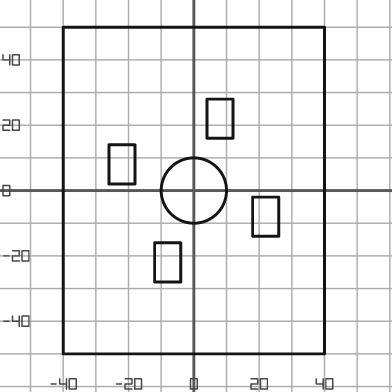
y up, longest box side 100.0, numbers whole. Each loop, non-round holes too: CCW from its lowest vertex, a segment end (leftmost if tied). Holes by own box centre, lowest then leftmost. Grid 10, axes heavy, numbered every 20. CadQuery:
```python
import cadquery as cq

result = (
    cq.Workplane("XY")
    .moveTo(-40.0, -50.0)
    .lineTo(40.0, -50.0)
    .lineTo(40.0, 50.0)
    .lineTo(-40.0, 50.0)
    .close()
    .moveTo(-12.0, -28.0)
    .lineTo(-4.0, -28.0)
    .lineTo(-4.0, -16.0)
    .lineTo(-12.0, -16.0)
    .close()
    .moveTo(18.0, -14.0)
    .lineTo(26.0, -14.0)
    .lineTo(26.0, -2.0)
    .lineTo(18.0, -2.0)
    .close()
    .moveTo(0.0, 0.0)
    .circle(10.0)
    .moveTo(-26.0, 2.0)
    .lineTo(-18.0, 2.0)
    .lineTo(-18.0, 14.0)
    .lineTo(-26.0, 14.0)
    .close()
    .moveTo(4.0, 16.0)
    .lineTo(12.0, 16.0)
    .lineTo(12.0, 28.0)
    .lineTo(4.0, 28.0)
    .close()
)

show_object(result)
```